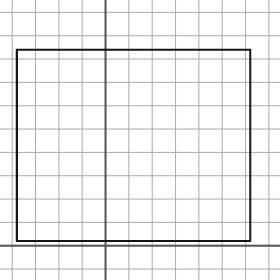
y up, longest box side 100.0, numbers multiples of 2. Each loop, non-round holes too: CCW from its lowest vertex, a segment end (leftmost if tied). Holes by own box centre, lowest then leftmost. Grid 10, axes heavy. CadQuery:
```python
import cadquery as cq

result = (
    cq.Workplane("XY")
    .moveTo(-38.0, 2.0)
    .lineTo(62.0, 2.0)
    .lineTo(62.0, 84.0)
    .lineTo(-38.0, 84.0)
    .close()
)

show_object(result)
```